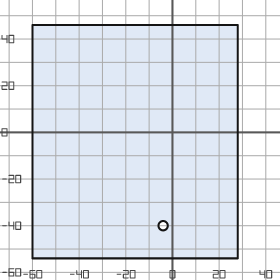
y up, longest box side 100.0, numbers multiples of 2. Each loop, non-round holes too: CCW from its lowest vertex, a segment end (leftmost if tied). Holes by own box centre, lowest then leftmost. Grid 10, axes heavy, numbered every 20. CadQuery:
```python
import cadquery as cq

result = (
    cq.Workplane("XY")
    .moveTo(-60.0, -54.0)
    .lineTo(28.0, -54.0)
    .lineTo(28.0, 46.0)
    .lineTo(-60.0, 46.0)
    .close()
    .moveTo(-4.0, -40.0)
    .circle(2.0)
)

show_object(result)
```